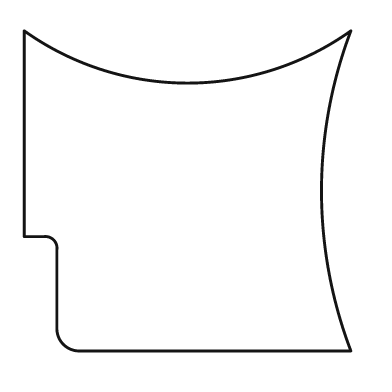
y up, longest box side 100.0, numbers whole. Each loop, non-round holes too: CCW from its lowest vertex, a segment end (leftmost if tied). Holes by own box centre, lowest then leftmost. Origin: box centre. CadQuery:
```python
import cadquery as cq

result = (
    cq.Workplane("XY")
    .moveTo(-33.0, -49.0)
    .lineTo(50.0, -49.0)
    .threePointArc((41.0, 0.0), (50.0, 49.0))
    .threePointArc((0.0, 33.0), (-50.0, 49.0))
    .lineTo(-50.0, -14.0)
    .lineTo(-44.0, -14.0)
    .threePointArc((-41.0, -15.0), (-40.0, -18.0))
    .lineTo(-40.0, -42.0)
    .threePointArc((-38.0, -47.0), (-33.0, -49.0))
    .close()
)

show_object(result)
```